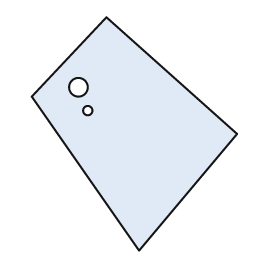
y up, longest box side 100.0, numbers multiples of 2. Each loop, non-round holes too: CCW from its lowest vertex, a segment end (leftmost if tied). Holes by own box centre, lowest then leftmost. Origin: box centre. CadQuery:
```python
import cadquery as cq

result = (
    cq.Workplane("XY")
    .moveTo(2.0, -50.0)
    .lineTo(44.0, 0.0)
    .lineTo(-12.0, 50.0)
    .lineTo(-44.0, 16.0)
    .close()
    .moveTo(-20.0, 10.0)
    .circle(2.0)
    .moveTo(-24.0, 20.0)
    .circle(4.0)
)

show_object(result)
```